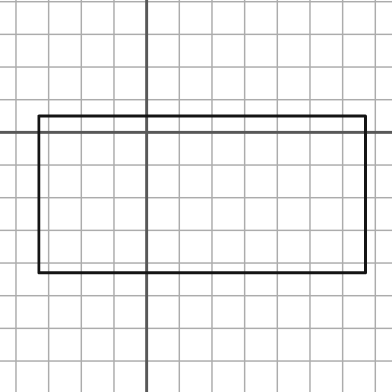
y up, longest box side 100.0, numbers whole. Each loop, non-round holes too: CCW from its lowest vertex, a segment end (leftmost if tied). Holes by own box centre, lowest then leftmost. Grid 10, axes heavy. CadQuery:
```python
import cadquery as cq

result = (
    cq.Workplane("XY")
    .moveTo(-33.0, -43.0)
    .lineTo(67.0, -43.0)
    .lineTo(67.0, 5.0)
    .lineTo(-33.0, 5.0)
    .close()
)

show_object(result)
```